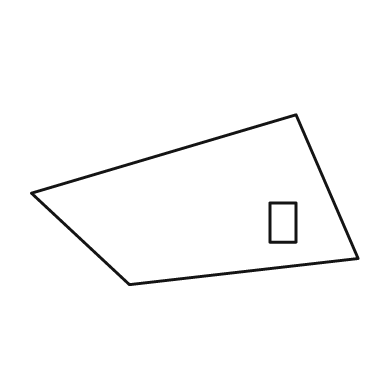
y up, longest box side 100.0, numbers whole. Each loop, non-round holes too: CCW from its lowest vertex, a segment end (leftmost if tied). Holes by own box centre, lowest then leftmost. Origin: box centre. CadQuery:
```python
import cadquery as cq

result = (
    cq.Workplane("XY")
    .moveTo(-20.0, -26.0)
    .lineTo(50.0, -18.0)
    .lineTo(31.0, 26.0)
    .lineTo(-50.0, 2.0)
    .close()
    .moveTo(23.0, -13.0)
    .lineTo(31.0, -13.0)
    .lineTo(31.0, -1.0)
    .lineTo(23.0, -1.0)
    .close()
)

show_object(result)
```